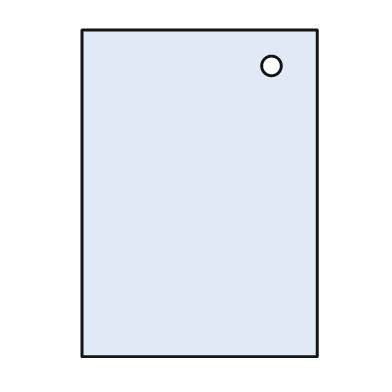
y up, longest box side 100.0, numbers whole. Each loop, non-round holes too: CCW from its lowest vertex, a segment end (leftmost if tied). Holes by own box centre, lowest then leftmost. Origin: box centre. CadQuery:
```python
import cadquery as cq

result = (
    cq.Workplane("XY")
    .moveTo(-36.0, -50.0)
    .lineTo(36.0, -50.0)
    .lineTo(36.0, 50.0)
    .lineTo(-36.0, 50.0)
    .close()
    .moveTo(22.0, 39.0)
    .circle(3.0)
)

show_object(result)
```